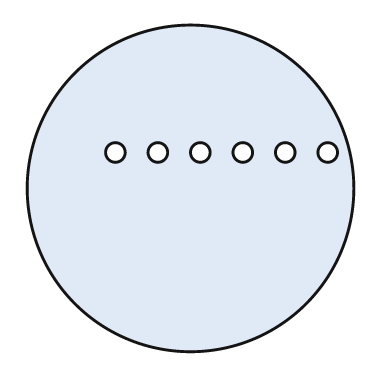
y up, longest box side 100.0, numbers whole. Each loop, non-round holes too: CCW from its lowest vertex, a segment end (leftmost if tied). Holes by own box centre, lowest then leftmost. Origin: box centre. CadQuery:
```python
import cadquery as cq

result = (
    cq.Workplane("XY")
    .moveTo(0.0, 0.0)
    .circle(50.0)
    .moveTo(-23.0, 11.0)
    .circle(3.0)
    .moveTo(-10.0, 11.0)
    .circle(3.0)
    .moveTo(3.0, 11.0)
    .circle(3.0)
    .moveTo(16.0, 11.0)
    .circle(3.0)
    .moveTo(29.0, 11.0)
    .circle(3.0)
    .moveTo(42.0, 11.0)
    .circle(3.0)
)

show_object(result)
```